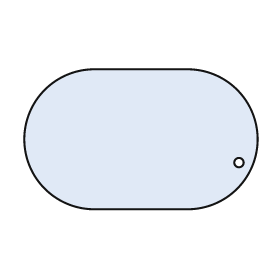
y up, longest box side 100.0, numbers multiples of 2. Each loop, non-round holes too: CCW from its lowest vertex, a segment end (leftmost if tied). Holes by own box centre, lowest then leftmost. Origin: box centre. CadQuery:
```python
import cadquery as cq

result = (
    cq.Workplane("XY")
    .moveTo(-20.0, -30.0)
    .lineTo(20.0, -30.0)
    .threePointArc((50.0, 0.0), (20.0, 30.0))
    .lineTo(-20.0, 30.0)
    .threePointArc((-50.0, 0.0), (-20.0, -30.0))
    .close()
    .moveTo(42.0, -10.0)
    .circle(2.0)
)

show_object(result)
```